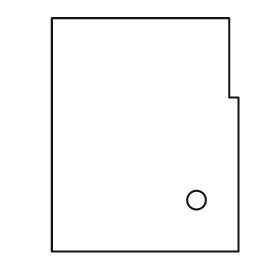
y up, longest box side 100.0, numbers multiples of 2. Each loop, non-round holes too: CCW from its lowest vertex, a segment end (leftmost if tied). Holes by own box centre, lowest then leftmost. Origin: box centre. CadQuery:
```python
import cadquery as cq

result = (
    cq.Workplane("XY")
    .moveTo(-40.0, -50.0)
    .lineTo(40.0, -50.0)
    .lineTo(40.0, 16.0)
    .lineTo(36.0, 16.0)
    .lineTo(36.0, 50.0)
    .lineTo(-40.0, 50.0)
    .close()
    .moveTo(22.0, -28.0)
    .circle(4.0)
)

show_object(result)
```